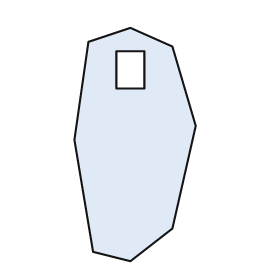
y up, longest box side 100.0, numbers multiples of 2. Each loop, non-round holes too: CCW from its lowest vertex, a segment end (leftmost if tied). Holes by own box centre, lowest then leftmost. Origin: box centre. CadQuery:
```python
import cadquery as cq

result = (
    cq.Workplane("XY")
    .moveTo(-2.0, -50.0)
    .lineTo(16.0, -36.0)
    .lineTo(26.0, 8.0)
    .lineTo(16.0, 42.0)
    .lineTo(-2.0, 50.0)
    .lineTo(-20.0, 44.0)
    .lineTo(-26.0, 2.0)
    .lineTo(-18.0, -46.0)
    .close()
    .moveTo(-8.0, 24.0)
    .lineTo(4.0, 24.0)
    .lineTo(4.0, 40.0)
    .lineTo(-8.0, 40.0)
    .close()
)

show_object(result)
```